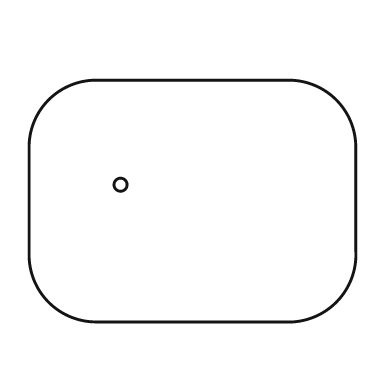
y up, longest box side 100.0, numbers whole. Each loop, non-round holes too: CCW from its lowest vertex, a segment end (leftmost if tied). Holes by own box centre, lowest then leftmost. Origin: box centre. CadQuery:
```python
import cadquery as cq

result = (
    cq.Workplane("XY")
    .moveTo(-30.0, -37.0)
    .lineTo(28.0, -37.0)
    .threePointArc((44.0, -31.0), (50.0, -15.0))
    .lineTo(50.0, 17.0)
    .threePointArc((44.0, 31.0), (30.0, 37.0))
    .lineTo(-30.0, 37.0)
    .threePointArc((-44.0, 31.0), (-50.0, 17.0))
    .lineTo(-50.0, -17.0)
    .threePointArc((-44.0, -31.0), (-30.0, -37.0))
    .close()
    .moveTo(-22.0, 5.0)
    .circle(2.0)
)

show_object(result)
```